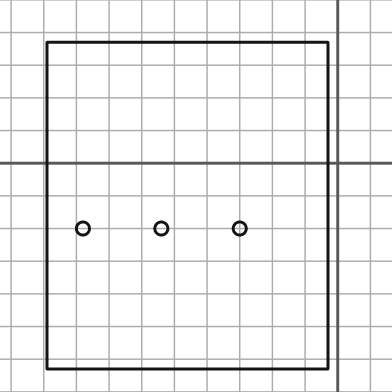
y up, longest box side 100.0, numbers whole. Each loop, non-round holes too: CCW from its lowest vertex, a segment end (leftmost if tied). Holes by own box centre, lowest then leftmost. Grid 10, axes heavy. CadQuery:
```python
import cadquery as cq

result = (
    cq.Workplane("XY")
    .moveTo(-89.0, -63.0)
    .lineTo(-3.0, -63.0)
    .lineTo(-3.0, 37.0)
    .lineTo(-89.0, 37.0)
    .close()
    .moveTo(-78.0, -20.0)
    .circle(2.0)
    .moveTo(-54.0, -20.0)
    .circle(2.0)
    .moveTo(-30.0, -20.0)
    .circle(2.0)
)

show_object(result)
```